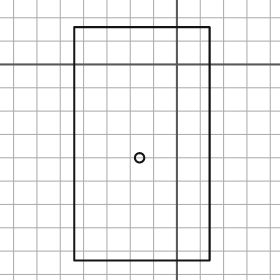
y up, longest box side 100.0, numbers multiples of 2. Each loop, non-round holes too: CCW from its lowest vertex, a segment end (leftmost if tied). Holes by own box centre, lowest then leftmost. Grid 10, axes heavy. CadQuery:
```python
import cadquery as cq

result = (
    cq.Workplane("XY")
    .moveTo(-44.0, -84.0)
    .lineTo(14.0, -84.0)
    .lineTo(14.0, 16.0)
    .lineTo(-44.0, 16.0)
    .close()
    .moveTo(-16.0, -40.0)
    .circle(2.0)
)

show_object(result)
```